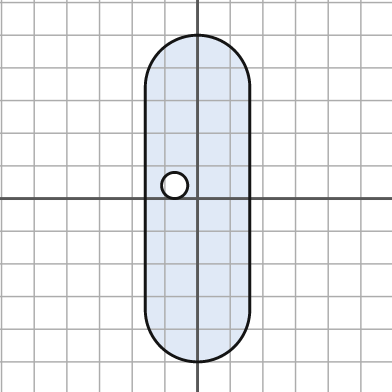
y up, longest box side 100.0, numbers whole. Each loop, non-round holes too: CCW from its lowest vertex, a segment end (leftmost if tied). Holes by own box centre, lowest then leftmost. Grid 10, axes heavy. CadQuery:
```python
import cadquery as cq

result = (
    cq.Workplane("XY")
    .moveTo(-16.0, -34.0)
    .threePointArc((0.0, -50.0), (16.0, -34.0))
    .lineTo(16.0, 34.0)
    .threePointArc((0.0, 50.0), (-16.0, 34.0))
    .close()
    .moveTo(-7.0, 4.0)
    .circle(4.0)
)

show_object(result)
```